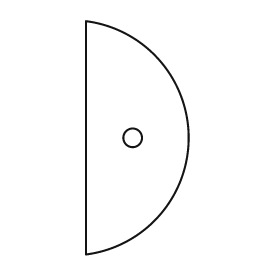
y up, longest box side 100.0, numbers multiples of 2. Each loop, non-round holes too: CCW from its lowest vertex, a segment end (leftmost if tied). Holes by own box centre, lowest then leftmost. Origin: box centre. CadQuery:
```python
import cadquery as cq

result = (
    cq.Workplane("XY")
    .moveTo(-22.0, -50.0)
    .threePointArc((22.0, 0.0), (-22.0, 50.0))
    .close()
    .moveTo(-2.0, 0.0)
    .circle(4.0)
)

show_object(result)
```